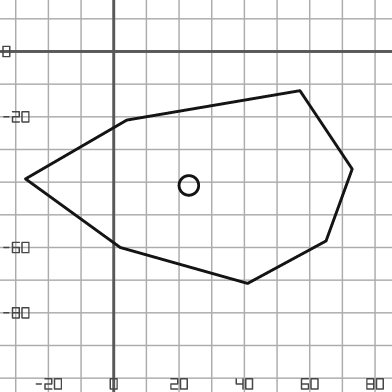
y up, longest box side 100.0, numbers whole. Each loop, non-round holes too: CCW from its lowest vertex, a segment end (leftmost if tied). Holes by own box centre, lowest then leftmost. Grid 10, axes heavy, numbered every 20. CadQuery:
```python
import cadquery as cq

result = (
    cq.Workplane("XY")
    .moveTo(41.0, -71.0)
    .lineTo(65.0, -58.0)
    .lineTo(73.0, -36.0)
    .lineTo(57.0, -12.0)
    .lineTo(4.0, -21.0)
    .lineTo(-27.0, -39.0)
    .lineTo(2.0, -60.0)
    .close()
    .moveTo(23.0, -41.0)
    .circle(3.0)
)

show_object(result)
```